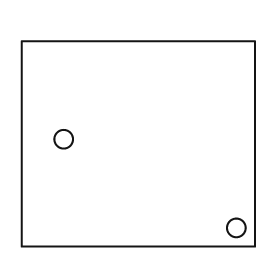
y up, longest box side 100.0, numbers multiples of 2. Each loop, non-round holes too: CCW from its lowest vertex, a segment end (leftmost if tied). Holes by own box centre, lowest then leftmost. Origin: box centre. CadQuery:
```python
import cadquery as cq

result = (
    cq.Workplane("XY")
    .moveTo(-50.0, -44.0)
    .lineTo(50.0, -44.0)
    .lineTo(50.0, 44.0)
    .lineTo(-50.0, 44.0)
    .close()
    .moveTo(42.0, -36.0)
    .circle(4.0)
    .moveTo(-32.0, 2.0)
    .circle(4.0)
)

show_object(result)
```